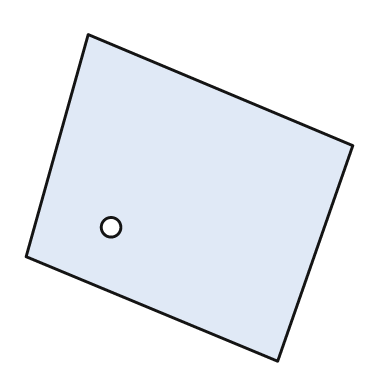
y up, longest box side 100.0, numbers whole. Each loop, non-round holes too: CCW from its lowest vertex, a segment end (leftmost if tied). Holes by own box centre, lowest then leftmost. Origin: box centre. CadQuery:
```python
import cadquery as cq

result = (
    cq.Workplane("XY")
    .moveTo(27.0, -50.0)
    .lineTo(50.0, 16.0)
    .lineTo(-31.0, 50.0)
    .lineTo(-50.0, -18.0)
    .close()
    .moveTo(-24.0, -9.0)
    .circle(3.0)
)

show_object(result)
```